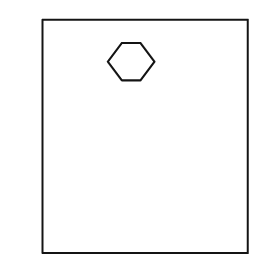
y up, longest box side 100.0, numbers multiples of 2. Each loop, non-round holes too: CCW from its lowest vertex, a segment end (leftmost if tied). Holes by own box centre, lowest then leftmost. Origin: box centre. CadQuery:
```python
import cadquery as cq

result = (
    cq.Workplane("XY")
    .moveTo(-44.0, -50.0)
    .lineTo(44.0, -50.0)
    .lineTo(44.0, 50.0)
    .lineTo(-44.0, 50.0)
    .close()
    .moveTo(-10.0, 24.0)
    .lineTo(-2.0, 24.0)
    .lineTo(4.0, 32.0)
    .lineTo(-2.0, 40.0)
    .lineTo(-10.0, 40.0)
    .lineTo(-16.0, 32.0)
    .close()
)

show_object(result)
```